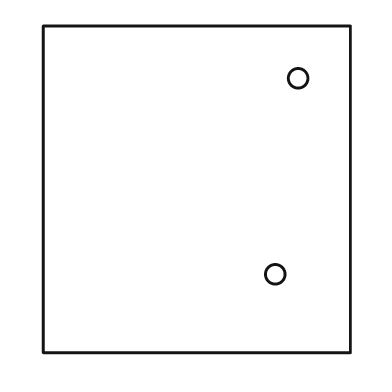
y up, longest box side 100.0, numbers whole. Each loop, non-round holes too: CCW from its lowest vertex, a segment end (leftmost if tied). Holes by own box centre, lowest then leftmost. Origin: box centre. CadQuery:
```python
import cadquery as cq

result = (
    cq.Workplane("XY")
    .moveTo(-47.0, -50.0)
    .lineTo(47.0, -50.0)
    .lineTo(47.0, 50.0)
    .lineTo(-47.0, 50.0)
    .close()
    .moveTo(24.0, -26.0)
    .circle(3.0)
    .moveTo(31.0, 34.0)
    .circle(3.0)
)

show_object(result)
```